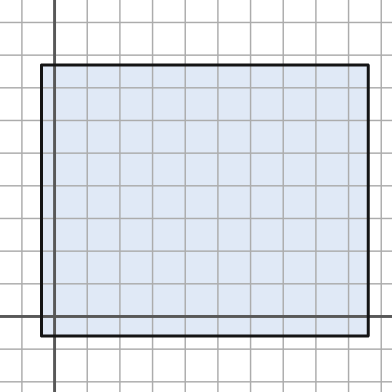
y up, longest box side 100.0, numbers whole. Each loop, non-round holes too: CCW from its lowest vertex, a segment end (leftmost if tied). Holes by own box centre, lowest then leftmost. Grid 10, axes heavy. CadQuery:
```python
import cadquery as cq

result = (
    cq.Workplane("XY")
    .moveTo(-4.0, -6.0)
    .lineTo(96.0, -6.0)
    .lineTo(96.0, 77.0)
    .lineTo(-4.0, 77.0)
    .close()
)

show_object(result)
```